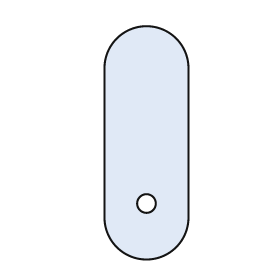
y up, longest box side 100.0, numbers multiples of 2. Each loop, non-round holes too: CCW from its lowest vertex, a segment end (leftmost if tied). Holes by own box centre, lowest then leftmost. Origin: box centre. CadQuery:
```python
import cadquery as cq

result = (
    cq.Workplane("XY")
    .moveTo(-18.0, -32.0)
    .threePointArc((0.0, -50.0), (18.0, -32.0))
    .lineTo(18.0, 32.0)
    .threePointArc((0.0, 50.0), (-18.0, 32.0))
    .close()
    .moveTo(0.0, -26.0)
    .circle(4.0)
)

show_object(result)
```